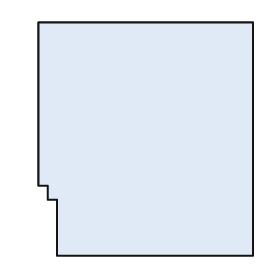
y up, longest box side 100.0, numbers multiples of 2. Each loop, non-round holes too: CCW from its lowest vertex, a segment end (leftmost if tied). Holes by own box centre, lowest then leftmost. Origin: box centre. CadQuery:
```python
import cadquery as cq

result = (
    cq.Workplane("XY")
    .moveTo(-38.0, -50.0)
    .lineTo(46.0, -50.0)
    .lineTo(46.0, 50.0)
    .lineTo(-46.0, 50.0)
    .lineTo(-46.0, -20.0)
    .lineTo(-42.0, -20.0)
    .lineTo(-42.0, -26.0)
    .lineTo(-38.0, -26.0)
    .close()
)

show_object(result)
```